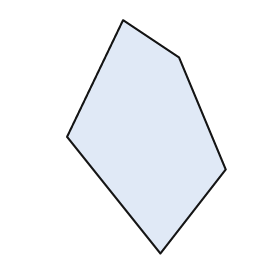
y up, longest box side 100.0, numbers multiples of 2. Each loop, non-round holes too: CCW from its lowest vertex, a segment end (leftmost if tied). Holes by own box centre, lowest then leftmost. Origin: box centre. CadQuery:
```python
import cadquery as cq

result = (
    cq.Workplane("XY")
    .moveTo(6.0, -50.0)
    .lineTo(34.0, -14.0)
    .lineTo(14.0, 34.0)
    .lineTo(-10.0, 50.0)
    .lineTo(-34.0, 0.0)
    .close()
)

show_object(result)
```